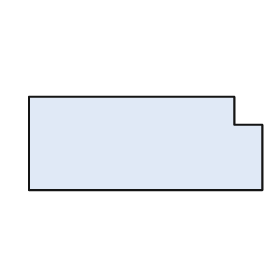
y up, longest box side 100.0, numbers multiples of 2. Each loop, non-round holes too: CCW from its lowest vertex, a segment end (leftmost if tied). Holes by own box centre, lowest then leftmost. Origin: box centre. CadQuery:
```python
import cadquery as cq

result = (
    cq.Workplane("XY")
    .moveTo(-50.0, -20.0)
    .lineTo(50.0, -20.0)
    .lineTo(50.0, 8.0)
    .lineTo(38.0, 8.0)
    .lineTo(38.0, 20.0)
    .lineTo(-50.0, 20.0)
    .close()
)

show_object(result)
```